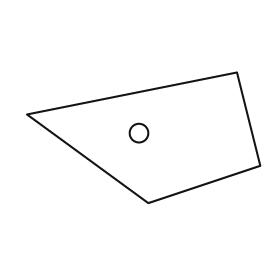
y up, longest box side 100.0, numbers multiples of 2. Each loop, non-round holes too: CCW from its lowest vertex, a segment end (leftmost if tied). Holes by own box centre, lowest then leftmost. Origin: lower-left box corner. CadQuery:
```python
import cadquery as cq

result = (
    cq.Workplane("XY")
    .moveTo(52.0, 0.0)
    .lineTo(100.0, 16.0)
    .lineTo(90.0, 56.0)
    .lineTo(0.0, 38.0)
    .close()
    .moveTo(48.0, 30.0)
    .circle(4.0)
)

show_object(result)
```